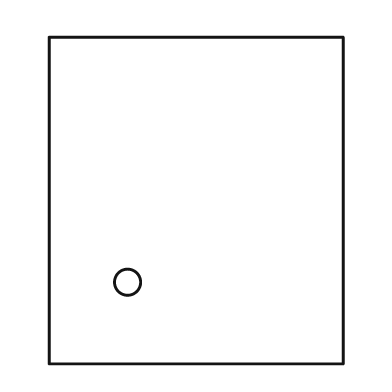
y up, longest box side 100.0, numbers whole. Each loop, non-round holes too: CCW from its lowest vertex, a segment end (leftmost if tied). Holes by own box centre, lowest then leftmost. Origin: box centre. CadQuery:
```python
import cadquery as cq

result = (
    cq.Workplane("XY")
    .moveTo(-45.0, -50.0)
    .lineTo(45.0, -50.0)
    .lineTo(45.0, 50.0)
    .lineTo(-45.0, 50.0)
    .close()
    .moveTo(-21.0, -25.0)
    .circle(4.0)
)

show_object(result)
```